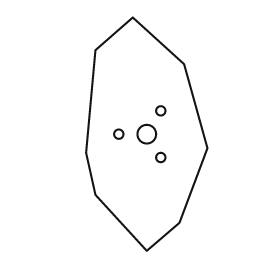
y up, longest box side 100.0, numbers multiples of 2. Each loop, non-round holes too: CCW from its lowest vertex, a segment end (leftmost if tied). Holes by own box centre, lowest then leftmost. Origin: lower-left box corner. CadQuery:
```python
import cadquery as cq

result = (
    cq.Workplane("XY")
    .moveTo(26.0, 0.0)
    .lineTo(40.0, 12.0)
    .lineTo(52.0, 44.0)
    .lineTo(42.0, 80.0)
    .lineTo(20.0, 100.0)
    .lineTo(4.0, 86.0)
    .lineTo(0.0, 42.0)
    .lineTo(4.0, 24.0)
    .close()
    .moveTo(32.0, 40.0)
    .circle(2.0)
    .moveTo(14.0, 50.0)
    .circle(2.0)
    .moveTo(26.0, 50.0)
    .circle(4.0)
    .moveTo(32.0, 60.0)
    .circle(2.0)
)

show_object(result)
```